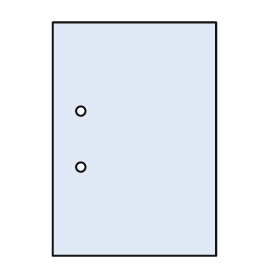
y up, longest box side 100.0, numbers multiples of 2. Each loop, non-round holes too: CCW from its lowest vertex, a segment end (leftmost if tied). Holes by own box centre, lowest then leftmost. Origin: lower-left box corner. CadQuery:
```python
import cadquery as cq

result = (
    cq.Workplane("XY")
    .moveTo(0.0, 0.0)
    .lineTo(70.0, 0.0)
    .lineTo(70.0, 100.0)
    .lineTo(0.0, 100.0)
    .close()
    .moveTo(12.0, 38.0)
    .circle(2.0)
    .moveTo(12.0, 62.0)
    .circle(2.0)
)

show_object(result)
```